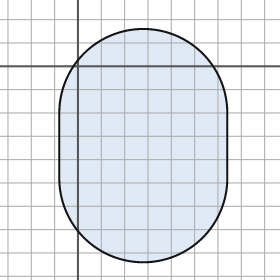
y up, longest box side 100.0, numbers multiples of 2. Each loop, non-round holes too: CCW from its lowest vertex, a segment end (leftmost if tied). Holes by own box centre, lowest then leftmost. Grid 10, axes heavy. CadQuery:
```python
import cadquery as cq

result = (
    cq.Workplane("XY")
    .moveTo(-8.0, -48.0)
    .threePointArc((28.0, -84.0), (64.0, -48.0))
    .lineTo(64.0, -20.0)
    .threePointArc((28.0, 16.0), (-8.0, -20.0))
    .close()
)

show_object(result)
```